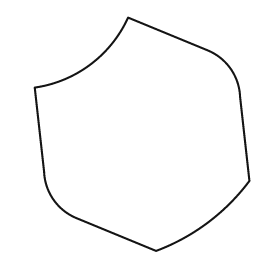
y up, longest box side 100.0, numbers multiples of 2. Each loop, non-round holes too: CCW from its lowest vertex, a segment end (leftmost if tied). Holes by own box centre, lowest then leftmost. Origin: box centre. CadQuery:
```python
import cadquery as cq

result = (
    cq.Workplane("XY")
    .moveTo(6.0, -50.0)
    .threePointArc((28.0, -38.0), (46.0, -20.0))
    .lineTo(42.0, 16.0)
    .threePointArc((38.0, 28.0), (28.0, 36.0))
    .lineTo(-6.0, 50.0)
    .threePointArc((-22.0, 30.0), (-46.0, 20.0))
    .lineTo(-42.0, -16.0)
    .threePointArc((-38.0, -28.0), (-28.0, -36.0))
    .close()
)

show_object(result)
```